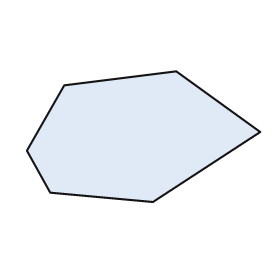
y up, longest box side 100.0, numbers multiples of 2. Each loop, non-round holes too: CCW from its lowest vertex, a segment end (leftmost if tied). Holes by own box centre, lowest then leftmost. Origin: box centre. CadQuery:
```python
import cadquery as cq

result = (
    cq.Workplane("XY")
    .moveTo(4.0, -28.0)
    .lineTo(50.0, 2.0)
    .lineTo(14.0, 28.0)
    .lineTo(-34.0, 22.0)
    .lineTo(-50.0, -6.0)
    .lineTo(-40.0, -24.0)
    .close()
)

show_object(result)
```